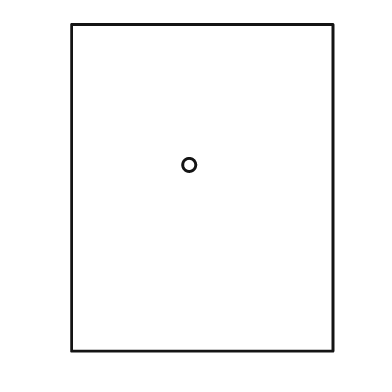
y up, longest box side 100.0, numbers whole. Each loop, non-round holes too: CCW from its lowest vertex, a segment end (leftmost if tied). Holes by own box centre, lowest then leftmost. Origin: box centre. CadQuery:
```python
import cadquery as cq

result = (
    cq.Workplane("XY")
    .moveTo(-40.0, -50.0)
    .lineTo(40.0, -50.0)
    .lineTo(40.0, 50.0)
    .lineTo(-40.0, 50.0)
    .close()
    .moveTo(-4.0, 7.0)
    .circle(2.0)
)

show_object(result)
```